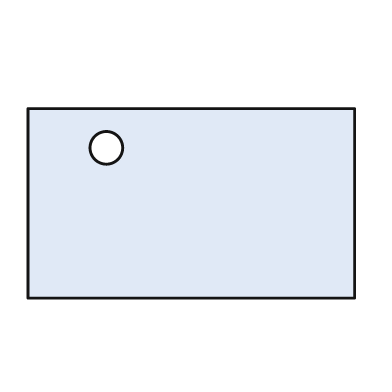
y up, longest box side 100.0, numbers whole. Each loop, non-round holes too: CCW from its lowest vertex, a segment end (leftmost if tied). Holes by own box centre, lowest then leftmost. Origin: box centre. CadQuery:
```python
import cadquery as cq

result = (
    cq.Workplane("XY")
    .moveTo(-50.0, -29.0)
    .lineTo(50.0, -29.0)
    .lineTo(50.0, 29.0)
    .lineTo(-50.0, 29.0)
    .close()
    .moveTo(-26.0, 17.0)
    .circle(5.0)
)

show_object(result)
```